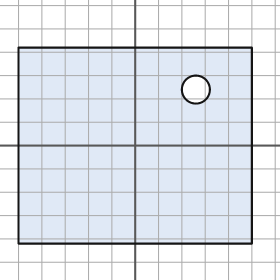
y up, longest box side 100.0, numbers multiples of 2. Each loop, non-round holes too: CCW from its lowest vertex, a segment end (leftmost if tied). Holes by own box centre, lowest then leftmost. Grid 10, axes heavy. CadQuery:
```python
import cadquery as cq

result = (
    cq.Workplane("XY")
    .moveTo(-50.0, -42.0)
    .lineTo(50.0, -42.0)
    .lineTo(50.0, 42.0)
    .lineTo(-50.0, 42.0)
    .close()
    .moveTo(26.0, 24.0)
    .circle(6.0)
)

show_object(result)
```